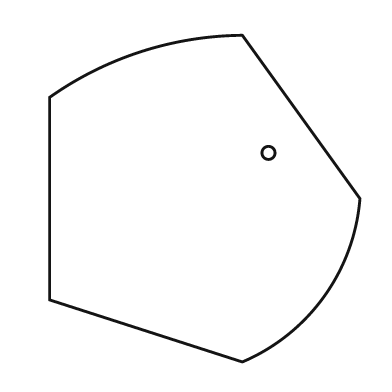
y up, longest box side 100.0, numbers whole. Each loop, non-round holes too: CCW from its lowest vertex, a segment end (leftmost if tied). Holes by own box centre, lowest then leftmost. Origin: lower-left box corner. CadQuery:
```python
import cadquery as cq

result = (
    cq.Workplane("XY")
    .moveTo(59.0, 0.0)
    .threePointArc((84.0, 20.0), (95.0, 50.0))
    .lineTo(59.0, 100.0)
    .threePointArc((28.0, 95.0), (0.0, 81.0))
    .lineTo(0.0, 19.0)
    .close()
    .moveTo(67.0, 64.0)
    .circle(2.0)
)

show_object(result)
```